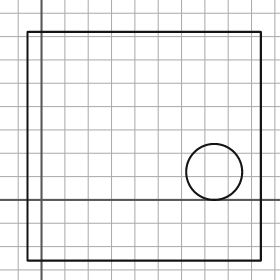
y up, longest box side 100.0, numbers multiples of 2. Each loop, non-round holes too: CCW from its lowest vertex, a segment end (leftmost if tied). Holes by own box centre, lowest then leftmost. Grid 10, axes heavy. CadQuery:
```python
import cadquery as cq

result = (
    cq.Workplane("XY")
    .moveTo(-6.0, -26.0)
    .lineTo(94.0, -26.0)
    .lineTo(94.0, 72.0)
    .lineTo(-6.0, 72.0)
    .close()
    .moveTo(74.0, 12.0)
    .circle(12.0)
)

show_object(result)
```